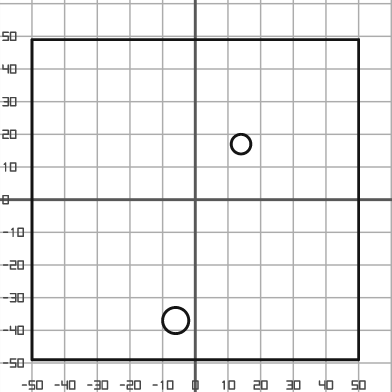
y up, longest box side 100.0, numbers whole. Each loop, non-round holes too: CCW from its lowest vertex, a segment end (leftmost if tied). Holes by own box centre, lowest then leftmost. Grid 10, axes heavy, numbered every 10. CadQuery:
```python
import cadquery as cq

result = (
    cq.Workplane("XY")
    .moveTo(-50.0, -49.0)
    .lineTo(50.0, -49.0)
    .lineTo(50.0, 49.0)
    .lineTo(-50.0, 49.0)
    .close()
    .moveTo(-6.0, -37.0)
    .circle(4.0)
    .moveTo(14.0, 17.0)
    .circle(3.0)
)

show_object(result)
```